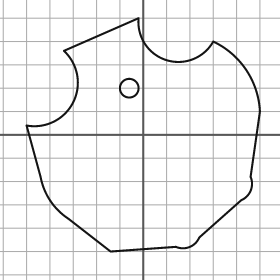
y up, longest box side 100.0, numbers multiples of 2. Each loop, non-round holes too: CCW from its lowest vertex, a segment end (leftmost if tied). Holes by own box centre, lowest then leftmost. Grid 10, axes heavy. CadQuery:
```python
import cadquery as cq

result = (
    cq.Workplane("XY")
    .moveTo(-14.0, -50.0)
    .lineTo(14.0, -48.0)
    .threePointArc((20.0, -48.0), (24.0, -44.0))
    .lineTo(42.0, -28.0)
    .threePointArc((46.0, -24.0), (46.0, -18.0))
    .lineTo(50.0, 10.0)
    .threePointArc((44.0, 28.0), (30.0, 40.0))
    .threePointArc((10.0, 32.0), (-2.0, 50.0))
    .lineTo(-34.0, 36.0)
    .threePointArc((-30.0, 14.0), (-50.0, 4.0))
    .lineTo(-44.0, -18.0)
    .threePointArc((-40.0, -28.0), (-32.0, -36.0))
    .close()
    .moveTo(-6.0, 20.0)
    .circle(4.0)
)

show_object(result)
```